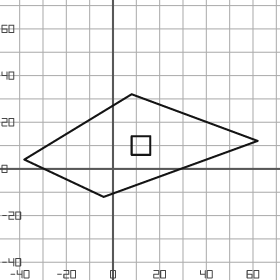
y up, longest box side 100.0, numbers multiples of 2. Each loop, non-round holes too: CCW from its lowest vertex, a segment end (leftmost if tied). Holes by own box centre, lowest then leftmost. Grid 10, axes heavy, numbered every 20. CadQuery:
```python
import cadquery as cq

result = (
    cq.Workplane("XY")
    .moveTo(-4.0, -12.0)
    .lineTo(62.0, 12.0)
    .lineTo(8.0, 32.0)
    .lineTo(-38.0, 4.0)
    .close()
    .moveTo(8.0, 6.0)
    .lineTo(16.0, 6.0)
    .lineTo(16.0, 14.0)
    .lineTo(8.0, 14.0)
    .close()
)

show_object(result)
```